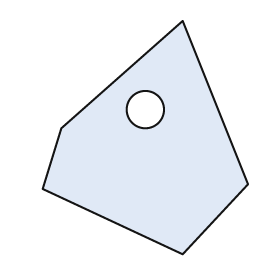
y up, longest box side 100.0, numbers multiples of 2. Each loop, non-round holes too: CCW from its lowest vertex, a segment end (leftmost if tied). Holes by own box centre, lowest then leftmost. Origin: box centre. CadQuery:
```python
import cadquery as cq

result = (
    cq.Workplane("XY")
    .moveTo(16.0, -50.0)
    .lineTo(44.0, -20.0)
    .lineTo(16.0, 50.0)
    .lineTo(-36.0, 4.0)
    .lineTo(-44.0, -22.0)
    .close()
    .moveTo(0.0, 12.0)
    .circle(8.0)
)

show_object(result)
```